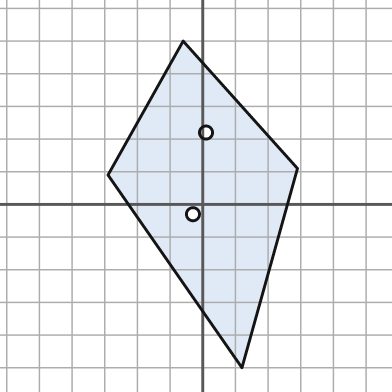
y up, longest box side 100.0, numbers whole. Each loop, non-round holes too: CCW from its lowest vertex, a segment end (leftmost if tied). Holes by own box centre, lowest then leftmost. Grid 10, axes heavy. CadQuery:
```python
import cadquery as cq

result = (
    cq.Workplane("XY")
    .moveTo(12.0, -50.0)
    .lineTo(29.0, 11.0)
    .lineTo(-6.0, 50.0)
    .lineTo(-29.0, 9.0)
    .close()
    .moveTo(-3.0, -3.0)
    .circle(2.0)
    .moveTo(1.0, 22.0)
    .circle(2.0)
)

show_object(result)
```